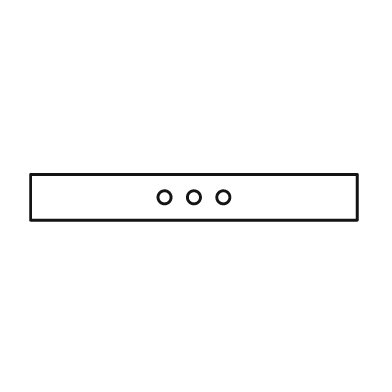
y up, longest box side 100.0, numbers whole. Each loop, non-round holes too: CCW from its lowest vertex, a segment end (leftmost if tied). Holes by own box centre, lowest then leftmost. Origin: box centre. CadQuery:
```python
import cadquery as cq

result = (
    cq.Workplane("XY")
    .moveTo(-50.0, -7.0)
    .lineTo(50.0, -7.0)
    .lineTo(50.0, 7.0)
    .lineTo(-50.0, 7.0)
    .close()
    .moveTo(-9.0, 0.0)
    .circle(2.0)
    .moveTo(0.0, 0.0)
    .circle(2.0)
    .moveTo(9.0, 0.0)
    .circle(2.0)
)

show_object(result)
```